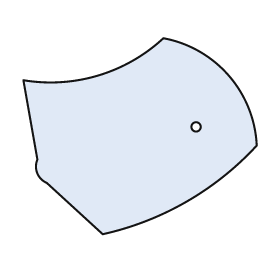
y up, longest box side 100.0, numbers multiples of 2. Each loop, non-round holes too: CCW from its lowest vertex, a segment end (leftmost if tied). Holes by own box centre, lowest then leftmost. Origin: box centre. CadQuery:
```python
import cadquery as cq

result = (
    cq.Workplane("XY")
    .moveTo(-16.0, -42.0)
    .threePointArc((20.0, -28.0), (50.0, -4.0))
    .threePointArc((38.0, 26.0), (10.0, 42.0))
    .threePointArc((-18.0, 26.0), (-50.0, 24.0))
    .lineTo(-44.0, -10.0)
    .threePointArc((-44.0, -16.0), (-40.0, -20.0))
    .close()
    .moveTo(24.0, 4.0)
    .circle(2.0)
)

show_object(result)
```